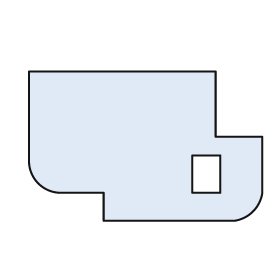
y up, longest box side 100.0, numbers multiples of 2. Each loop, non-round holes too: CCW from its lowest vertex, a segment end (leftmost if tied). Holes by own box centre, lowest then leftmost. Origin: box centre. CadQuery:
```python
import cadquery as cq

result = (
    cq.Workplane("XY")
    .moveTo(-18.0, -32.0)
    .lineTo(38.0, -32.0)
    .threePointArc((46.0, -28.0), (50.0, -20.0))
    .lineTo(50.0, 4.0)
    .lineTo(30.0, 4.0)
    .lineTo(30.0, 32.0)
    .lineTo(-50.0, 32.0)
    .lineTo(-50.0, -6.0)
    .threePointArc((-46.0, -16.0), (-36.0, -20.0))
    .lineTo(-18.0, -20.0)
    .close()
    .moveTo(20.0, -20.0)
    .lineTo(32.0, -20.0)
    .lineTo(32.0, -4.0)
    .lineTo(20.0, -4.0)
    .close()
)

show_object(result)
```